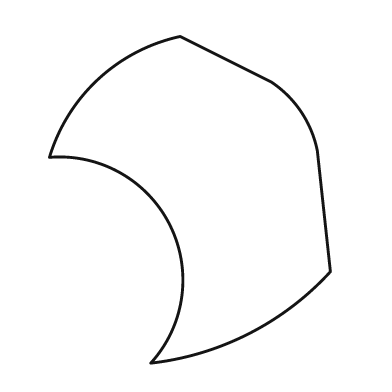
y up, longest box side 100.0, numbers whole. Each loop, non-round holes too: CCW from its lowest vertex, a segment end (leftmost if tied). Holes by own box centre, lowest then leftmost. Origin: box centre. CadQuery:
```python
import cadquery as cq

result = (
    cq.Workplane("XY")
    .moveTo(-12.0, -50.0)
    .threePointArc((18.0, -41.0), (43.0, -22.0))
    .lineTo(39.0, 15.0)
    .threePointArc((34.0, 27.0), (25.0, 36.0))
    .lineTo(-3.0, 50.0)
    .threePointArc((-28.0, 37.0), (-43.0, 13.0))
    .threePointArc((-6.0, -8.0), (-12.0, -50.0))
    .close()
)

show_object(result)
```